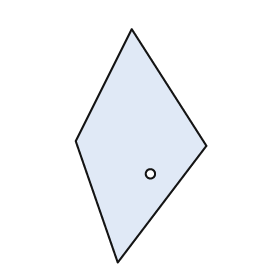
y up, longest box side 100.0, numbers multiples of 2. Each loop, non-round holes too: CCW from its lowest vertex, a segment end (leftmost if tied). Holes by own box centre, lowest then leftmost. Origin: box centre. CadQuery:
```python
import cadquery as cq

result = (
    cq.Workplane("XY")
    .moveTo(-10.0, -50.0)
    .lineTo(28.0, 0.0)
    .lineTo(-4.0, 50.0)
    .lineTo(-28.0, 2.0)
    .close()
    .moveTo(4.0, -12.0)
    .circle(2.0)
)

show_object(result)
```